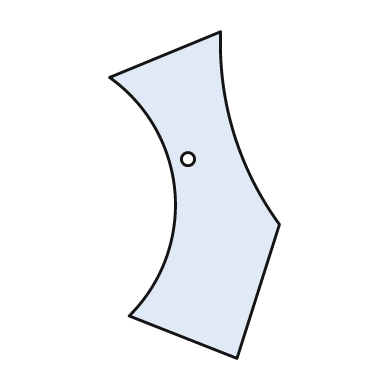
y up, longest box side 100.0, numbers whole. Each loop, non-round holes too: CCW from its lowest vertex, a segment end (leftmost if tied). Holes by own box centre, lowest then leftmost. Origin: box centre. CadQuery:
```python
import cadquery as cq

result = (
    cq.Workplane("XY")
    .moveTo(13.0, -50.0)
    .lineTo(26.0, -9.0)
    .threePointArc((12.0, 19.0), (8.0, 50.0))
    .lineTo(-26.0, 36.0)
    .threePointArc((-6.0, 1.0), (-20.0, -37.0))
    .close()
    .moveTo(-2.0, 11.0)
    .circle(2.0)
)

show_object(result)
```